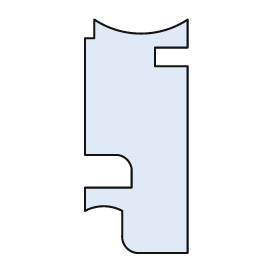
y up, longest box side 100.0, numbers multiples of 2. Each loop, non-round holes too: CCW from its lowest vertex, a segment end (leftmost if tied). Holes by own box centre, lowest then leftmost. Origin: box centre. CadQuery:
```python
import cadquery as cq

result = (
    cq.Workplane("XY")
    .moveTo(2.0, -50.0)
    .lineTo(22.0, -50.0)
    .lineTo(22.0, 30.0)
    .lineTo(8.0, 30.0)
    .lineTo(8.0, 38.0)
    .lineTo(22.0, 38.0)
    .lineTo(22.0, 50.0)
    .threePointArc((2.0, 44.0), (-18.0, 50.0))
    .lineTo(-18.0, 42.0)
    .lineTo(-22.0, 42.0)
    .lineTo(-22.0, -8.0)
    .lineTo(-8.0, -8.0)
    .threePointArc((-4.0, -10.0), (-2.0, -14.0))
    .lineTo(-2.0, -22.0)
    .lineTo(-22.0, -22.0)
    .lineTo(-22.0, -32.0)
    .threePointArc((-14.0, -30.0), (-6.0, -32.0))
    .lineTo(-6.0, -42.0)
    .threePointArc((-4.0, -48.0), (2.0, -50.0))
    .close()
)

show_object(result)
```